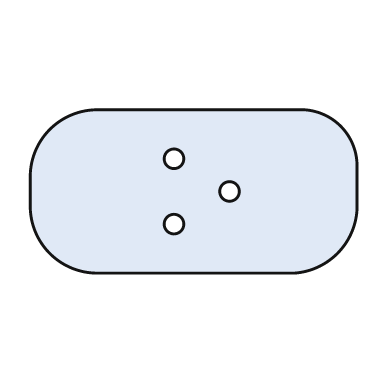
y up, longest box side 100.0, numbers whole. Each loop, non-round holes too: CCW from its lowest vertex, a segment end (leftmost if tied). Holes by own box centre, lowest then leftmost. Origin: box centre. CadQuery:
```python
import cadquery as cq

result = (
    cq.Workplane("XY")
    .moveTo(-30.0, -25.0)
    .lineTo(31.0, -25.0)
    .threePointArc((44.0, -19.0), (50.0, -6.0))
    .lineTo(50.0, 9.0)
    .threePointArc((45.0, 20.0), (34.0, 25.0))
    .lineTo(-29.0, 25.0)
    .threePointArc((-44.0, 19.0), (-50.0, 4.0))
    .lineTo(-50.0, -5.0)
    .threePointArc((-44.0, -19.0), (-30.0, -25.0))
    .close()
    .moveTo(-6.0, -10.0)
    .circle(3.0)
    .moveTo(11.0, 0.0)
    .circle(3.0)
    .moveTo(-6.0, 10.0)
    .circle(3.0)
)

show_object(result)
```